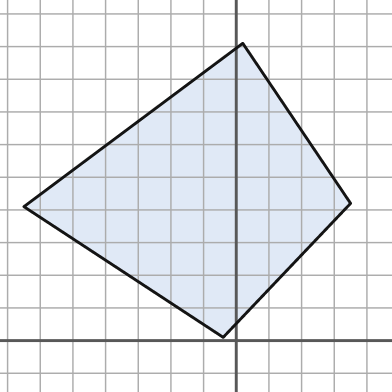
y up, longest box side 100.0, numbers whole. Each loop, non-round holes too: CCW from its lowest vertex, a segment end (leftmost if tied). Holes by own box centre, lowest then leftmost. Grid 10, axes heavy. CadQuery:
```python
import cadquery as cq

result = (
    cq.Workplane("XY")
    .moveTo(-4.0, 1.0)
    .lineTo(35.0, 42.0)
    .lineTo(2.0, 91.0)
    .lineTo(-65.0, 41.0)
    .close()
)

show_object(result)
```